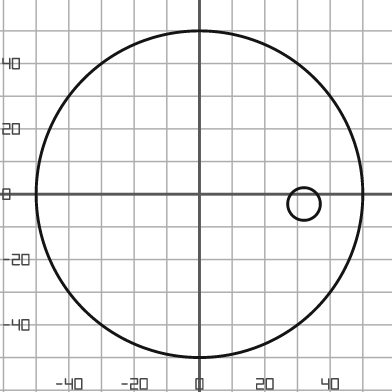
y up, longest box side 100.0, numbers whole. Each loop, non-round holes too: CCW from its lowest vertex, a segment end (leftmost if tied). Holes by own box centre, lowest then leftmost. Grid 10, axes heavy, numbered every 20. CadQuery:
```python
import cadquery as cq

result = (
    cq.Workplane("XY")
    .moveTo(0.0, 0.0)
    .circle(50.0)
    .moveTo(32.0, -3.0)
    .circle(5.0)
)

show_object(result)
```